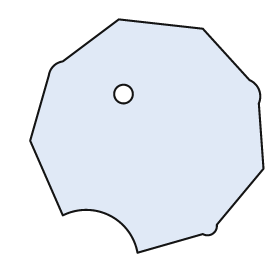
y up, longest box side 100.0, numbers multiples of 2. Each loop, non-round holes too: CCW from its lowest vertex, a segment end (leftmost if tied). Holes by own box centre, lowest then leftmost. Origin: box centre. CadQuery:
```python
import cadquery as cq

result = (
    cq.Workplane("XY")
    .moveTo(-4.0, -50.0)
    .lineTo(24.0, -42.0)
    .threePointArc((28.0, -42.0), (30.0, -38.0))
    .lineTo(50.0, -14.0)
    .lineTo(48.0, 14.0)
    .threePointArc((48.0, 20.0), (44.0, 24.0))
    .lineTo(24.0, 46.0)
    .lineTo(-12.0, 50.0)
    .lineTo(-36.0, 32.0)
    .threePointArc((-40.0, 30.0), (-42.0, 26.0))
    .lineTo(-50.0, -2.0)
    .lineTo(-36.0, -34.0)
    .threePointArc((-16.0, -34.0), (-4.0, -50.0))
    .close()
    .moveTo(-10.0, 18.0)
    .circle(4.0)
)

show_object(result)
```